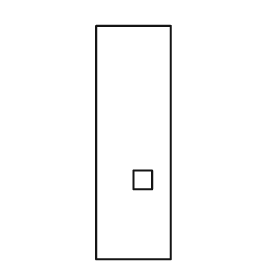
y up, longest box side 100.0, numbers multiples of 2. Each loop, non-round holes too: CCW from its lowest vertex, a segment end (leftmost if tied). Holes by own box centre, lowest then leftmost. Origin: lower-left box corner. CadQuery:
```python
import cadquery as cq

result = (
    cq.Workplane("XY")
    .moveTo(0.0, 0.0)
    .lineTo(32.0, 0.0)
    .lineTo(32.0, 100.0)
    .lineTo(0.0, 100.0)
    .close()
    .moveTo(16.0, 30.0)
    .lineTo(24.0, 30.0)
    .lineTo(24.0, 38.0)
    .lineTo(16.0, 38.0)
    .close()
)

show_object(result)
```